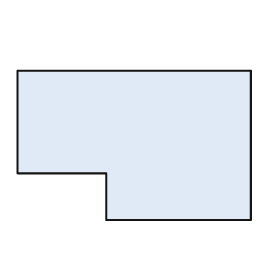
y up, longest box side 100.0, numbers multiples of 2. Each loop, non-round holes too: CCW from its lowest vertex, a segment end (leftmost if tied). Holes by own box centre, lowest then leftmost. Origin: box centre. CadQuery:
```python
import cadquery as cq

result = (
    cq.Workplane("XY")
    .moveTo(-12.0, -32.0)
    .lineTo(50.0, -32.0)
    .lineTo(50.0, 32.0)
    .lineTo(-50.0, 32.0)
    .lineTo(-50.0, -12.0)
    .lineTo(-12.0, -12.0)
    .close()
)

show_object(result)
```